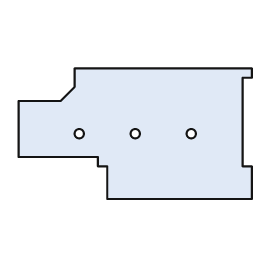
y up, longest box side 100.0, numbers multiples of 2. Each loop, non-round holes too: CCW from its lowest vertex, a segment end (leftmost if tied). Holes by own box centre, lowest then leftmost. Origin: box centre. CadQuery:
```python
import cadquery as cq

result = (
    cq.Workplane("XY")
    .moveTo(-12.0, -28.0)
    .lineTo(50.0, -28.0)
    .lineTo(50.0, -14.0)
    .lineTo(46.0, -14.0)
    .lineTo(46.0, 24.0)
    .lineTo(50.0, 24.0)
    .lineTo(50.0, 28.0)
    .lineTo(-26.0, 28.0)
    .lineTo(-26.0, 20.0)
    .lineTo(-32.0, 14.0)
    .lineTo(-50.0, 14.0)
    .lineTo(-50.0, -10.0)
    .lineTo(-16.0, -10.0)
    .lineTo(-16.0, -14.0)
    .lineTo(-12.0, -14.0)
    .close()
    .moveTo(-24.0, 0.0)
    .circle(2.0)
    .moveTo(0.0, 0.0)
    .circle(2.0)
    .moveTo(24.0, 0.0)
    .circle(2.0)
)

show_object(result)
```